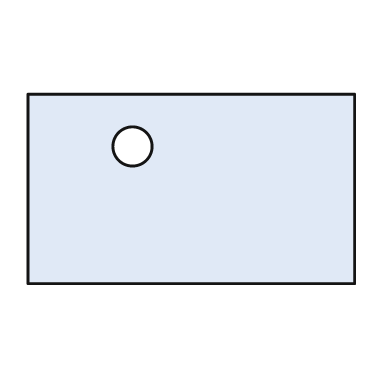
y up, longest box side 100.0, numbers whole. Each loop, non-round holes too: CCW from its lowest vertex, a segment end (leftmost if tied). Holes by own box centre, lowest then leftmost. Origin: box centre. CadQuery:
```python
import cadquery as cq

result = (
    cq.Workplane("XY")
    .moveTo(-50.0, -29.0)
    .lineTo(50.0, -29.0)
    .lineTo(50.0, 29.0)
    .lineTo(-50.0, 29.0)
    .close()
    .moveTo(-18.0, 13.0)
    .circle(6.0)
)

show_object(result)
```